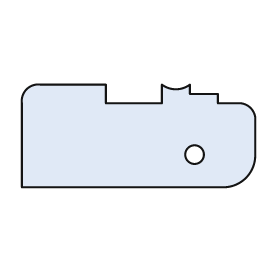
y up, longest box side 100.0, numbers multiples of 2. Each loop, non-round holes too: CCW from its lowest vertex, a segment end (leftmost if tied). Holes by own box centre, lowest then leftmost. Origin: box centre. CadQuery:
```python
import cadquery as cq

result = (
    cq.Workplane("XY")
    .moveTo(-50.0, -22.0)
    .lineTo(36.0, -22.0)
    .threePointArc((46.0, -18.0), (50.0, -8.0))
    .lineTo(50.0, 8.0)
    .threePointArc((48.0, 12.0), (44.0, 14.0))
    .lineTo(34.0, 14.0)
    .lineTo(34.0, 18.0)
    .lineTo(22.0, 18.0)
    .lineTo(22.0, 22.0)
    .threePointArc((16.0, 20.0), (10.0, 22.0))
    .lineTo(10.0, 14.0)
    .lineTo(-14.0, 14.0)
    .lineTo(-14.0, 22.0)
    .lineTo(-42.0, 22.0)
    .threePointArc((-48.0, 20.0), (-50.0, 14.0))
    .close()
    .moveTo(24.0, -8.0)
    .circle(4.0)
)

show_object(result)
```